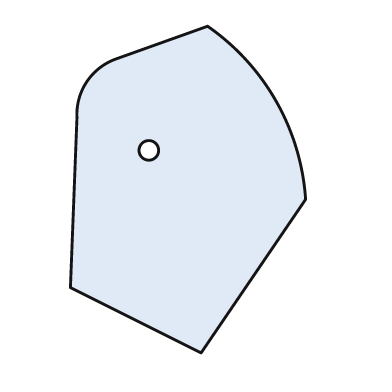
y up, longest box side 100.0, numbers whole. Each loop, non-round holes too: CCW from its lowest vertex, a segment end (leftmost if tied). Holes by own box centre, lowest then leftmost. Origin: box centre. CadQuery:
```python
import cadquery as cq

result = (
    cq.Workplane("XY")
    .moveTo(4.0, -50.0)
    .lineTo(36.0, -3.0)
    .threePointArc((27.0, 27.0), (6.0, 50.0))
    .lineTo(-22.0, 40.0)
    .threePointArc((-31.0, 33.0), (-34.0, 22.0))
    .lineTo(-36.0, -30.0)
    .close()
    .moveTo(-12.0, 12.0)
    .circle(3.0)
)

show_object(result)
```